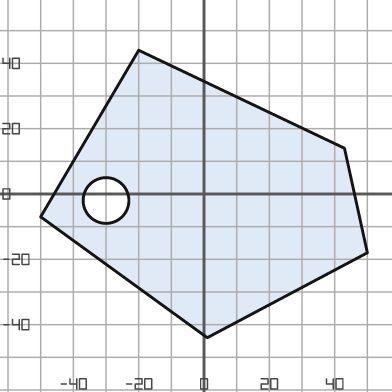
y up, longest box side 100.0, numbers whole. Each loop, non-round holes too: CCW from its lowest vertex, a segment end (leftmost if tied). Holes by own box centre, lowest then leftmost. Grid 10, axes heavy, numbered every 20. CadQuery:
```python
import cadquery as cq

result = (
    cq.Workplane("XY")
    .moveTo(1.0, -44.0)
    .lineTo(50.0, -18.0)
    .lineTo(43.0, 14.0)
    .lineTo(-20.0, 44.0)
    .lineTo(-50.0, -7.0)
    .close()
    .moveTo(-30.0, -2.0)
    .circle(7.0)
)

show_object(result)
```